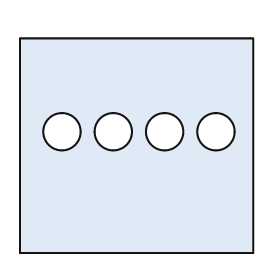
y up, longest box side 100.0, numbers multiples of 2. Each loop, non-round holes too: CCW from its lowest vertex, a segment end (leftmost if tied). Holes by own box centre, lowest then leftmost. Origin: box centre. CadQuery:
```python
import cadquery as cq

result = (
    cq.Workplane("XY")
    .moveTo(-50.0, -46.0)
    .lineTo(50.0, -46.0)
    .lineTo(50.0, 46.0)
    .lineTo(-50.0, 46.0)
    .close()
    .moveTo(-32.0, 6.0)
    .circle(8.0)
    .moveTo(-10.0, 6.0)
    .circle(8.0)
    .moveTo(12.0, 6.0)
    .circle(8.0)
    .moveTo(34.0, 6.0)
    .circle(8.0)
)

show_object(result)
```